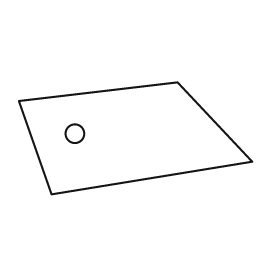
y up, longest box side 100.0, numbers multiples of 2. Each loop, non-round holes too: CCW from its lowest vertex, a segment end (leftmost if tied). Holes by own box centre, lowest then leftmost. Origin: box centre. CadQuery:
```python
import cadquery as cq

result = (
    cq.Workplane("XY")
    .moveTo(-36.0, -24.0)
    .lineTo(50.0, -10.0)
    .lineTo(18.0, 24.0)
    .lineTo(-50.0, 16.0)
    .close()
    .moveTo(-26.0, 2.0)
    .circle(4.0)
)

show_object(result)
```